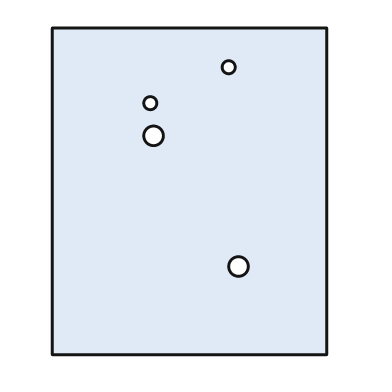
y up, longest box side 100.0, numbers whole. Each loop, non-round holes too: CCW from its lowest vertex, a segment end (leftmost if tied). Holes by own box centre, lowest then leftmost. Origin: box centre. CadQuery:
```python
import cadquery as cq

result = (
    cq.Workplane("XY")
    .moveTo(-42.0, -50.0)
    .lineTo(42.0, -50.0)
    .lineTo(42.0, 50.0)
    .lineTo(-42.0, 50.0)
    .close()
    .moveTo(15.0, -23.0)
    .circle(3.0)
    .moveTo(-11.0, 17.0)
    .circle(3.0)
    .moveTo(-12.0, 27.0)
    .circle(2.0)
    .moveTo(12.0, 38.0)
    .circle(2.0)
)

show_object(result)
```